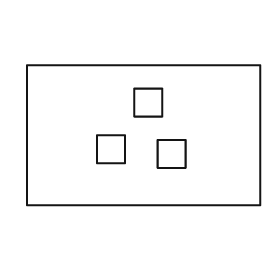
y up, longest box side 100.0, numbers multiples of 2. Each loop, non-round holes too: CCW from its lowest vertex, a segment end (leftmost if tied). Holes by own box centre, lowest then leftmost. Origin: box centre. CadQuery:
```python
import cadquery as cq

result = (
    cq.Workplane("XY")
    .moveTo(-50.0, -30.0)
    .lineTo(50.0, -30.0)
    .lineTo(50.0, 30.0)
    .lineTo(-50.0, 30.0)
    .close()
    .moveTo(6.0, -14.0)
    .lineTo(18.0, -14.0)
    .lineTo(18.0, -2.0)
    .lineTo(6.0, -2.0)
    .close()
    .moveTo(-20.0, -12.0)
    .lineTo(-8.0, -12.0)
    .lineTo(-8.0, 0.0)
    .lineTo(-20.0, 0.0)
    .close()
    .moveTo(-4.0, 8.0)
    .lineTo(8.0, 8.0)
    .lineTo(8.0, 20.0)
    .lineTo(-4.0, 20.0)
    .close()
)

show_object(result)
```